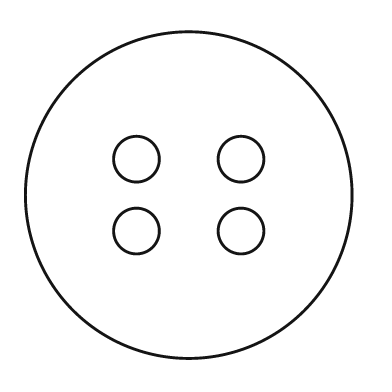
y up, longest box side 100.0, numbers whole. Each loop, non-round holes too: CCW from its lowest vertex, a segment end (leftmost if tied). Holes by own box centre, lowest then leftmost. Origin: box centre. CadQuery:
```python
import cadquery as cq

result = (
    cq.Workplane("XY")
    .moveTo(0.0, 0.0)
    .circle(50.0)
    .moveTo(-16.0, -11.0)
    .circle(7.0)
    .moveTo(16.0, -11.0)
    .circle(7.0)
    .moveTo(-16.0, 11.0)
    .circle(7.0)
    .moveTo(16.0, 11.0)
    .circle(7.0)
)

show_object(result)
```